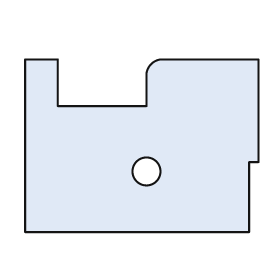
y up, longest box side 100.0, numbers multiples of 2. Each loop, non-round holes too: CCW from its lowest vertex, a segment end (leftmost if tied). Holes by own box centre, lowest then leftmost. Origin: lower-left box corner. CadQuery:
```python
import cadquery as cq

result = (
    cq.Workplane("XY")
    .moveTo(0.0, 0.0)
    .lineTo(96.0, 0.0)
    .lineTo(96.0, 30.0)
    .lineTo(100.0, 30.0)
    .lineTo(100.0, 74.0)
    .lineTo(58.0, 74.0)
    .threePointArc((54.0, 72.0), (52.0, 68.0))
    .lineTo(52.0, 54.0)
    .lineTo(14.0, 54.0)
    .lineTo(14.0, 74.0)
    .lineTo(0.0, 74.0)
    .close()
    .moveTo(52.0, 26.0)
    .circle(6.0)
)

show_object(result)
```